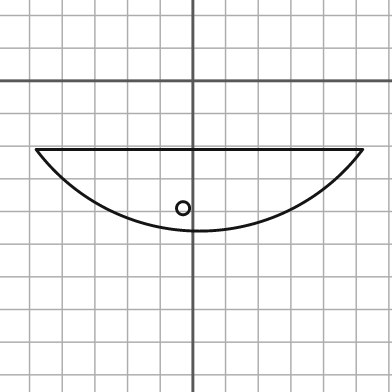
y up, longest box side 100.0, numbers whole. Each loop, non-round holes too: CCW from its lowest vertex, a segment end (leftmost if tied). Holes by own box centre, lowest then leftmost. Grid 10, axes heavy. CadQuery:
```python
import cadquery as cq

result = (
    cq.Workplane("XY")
    .moveTo(-48.0, -21.0)
    .threePointArc((2.0, -46.0), (52.0, -21.0))
    .close()
    .moveTo(-3.0, -39.0)
    .circle(2.0)
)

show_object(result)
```